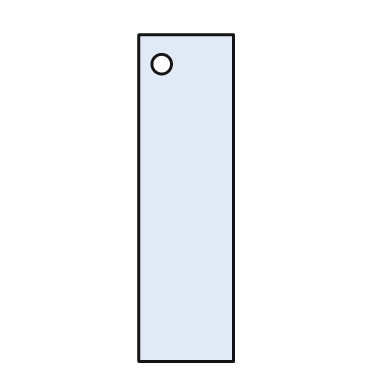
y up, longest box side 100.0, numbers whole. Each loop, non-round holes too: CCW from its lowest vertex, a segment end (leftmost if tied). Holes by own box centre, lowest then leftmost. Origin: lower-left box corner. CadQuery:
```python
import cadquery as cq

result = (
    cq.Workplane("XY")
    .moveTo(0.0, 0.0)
    .lineTo(29.0, 0.0)
    .lineTo(29.0, 100.0)
    .lineTo(0.0, 100.0)
    .close()
    .moveTo(7.0, 91.0)
    .circle(3.0)
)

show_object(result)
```